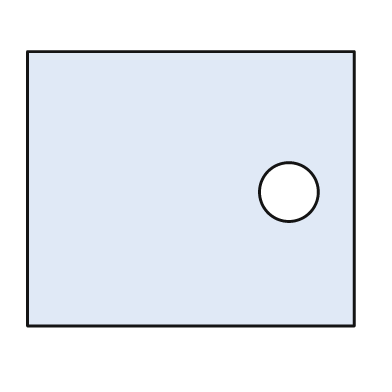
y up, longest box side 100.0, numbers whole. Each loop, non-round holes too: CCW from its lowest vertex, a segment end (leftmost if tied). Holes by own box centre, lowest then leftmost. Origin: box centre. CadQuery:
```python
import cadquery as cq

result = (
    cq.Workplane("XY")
    .moveTo(-50.0, -42.0)
    .lineTo(50.0, -42.0)
    .lineTo(50.0, 42.0)
    .lineTo(-50.0, 42.0)
    .close()
    .moveTo(30.0, -1.0)
    .circle(9.0)
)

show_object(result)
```